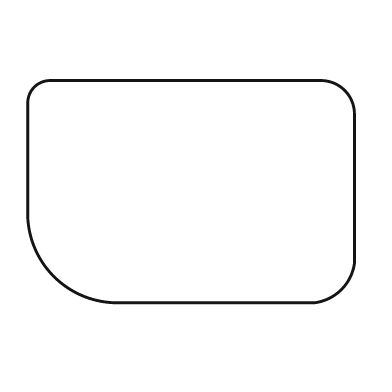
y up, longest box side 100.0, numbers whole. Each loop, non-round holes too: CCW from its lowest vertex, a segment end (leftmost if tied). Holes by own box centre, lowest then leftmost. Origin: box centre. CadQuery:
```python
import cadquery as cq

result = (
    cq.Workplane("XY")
    .moveTo(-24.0, -34.0)
    .lineTo(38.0, -34.0)
    .threePointArc((46.0, -30.0), (50.0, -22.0))
    .lineTo(50.0, 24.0)
    .threePointArc((47.0, 31.0), (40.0, 34.0))
    .lineTo(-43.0, 34.0)
    .threePointArc((-48.0, 32.0), (-50.0, 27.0))
    .lineTo(-50.0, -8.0)
    .threePointArc((-42.0, -26.0), (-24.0, -34.0))
    .close()
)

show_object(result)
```